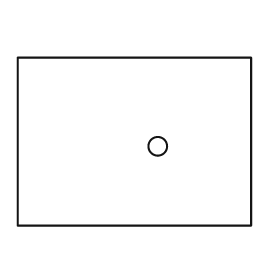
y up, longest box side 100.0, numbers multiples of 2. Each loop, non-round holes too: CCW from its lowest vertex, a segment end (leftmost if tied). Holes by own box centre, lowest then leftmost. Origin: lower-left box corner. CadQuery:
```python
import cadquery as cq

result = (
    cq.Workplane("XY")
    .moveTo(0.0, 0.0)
    .lineTo(100.0, 0.0)
    .lineTo(100.0, 72.0)
    .lineTo(0.0, 72.0)
    .close()
    .moveTo(60.0, 34.0)
    .circle(4.0)
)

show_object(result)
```